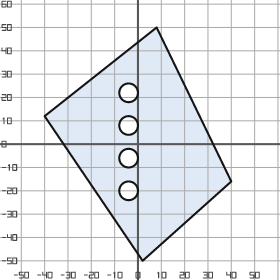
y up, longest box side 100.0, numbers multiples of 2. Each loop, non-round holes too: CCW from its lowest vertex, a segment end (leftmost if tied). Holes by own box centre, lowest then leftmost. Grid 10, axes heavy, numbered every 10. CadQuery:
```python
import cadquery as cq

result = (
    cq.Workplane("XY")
    .moveTo(2.0, -50.0)
    .lineTo(40.0, -16.0)
    .lineTo(8.0, 50.0)
    .lineTo(-40.0, 12.0)
    .close()
    .moveTo(-4.0, -20.0)
    .circle(4.0)
    .moveTo(-4.0, -6.0)
    .circle(4.0)
    .moveTo(-4.0, 8.0)
    .circle(4.0)
    .moveTo(-4.0, 22.0)
    .circle(4.0)
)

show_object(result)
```